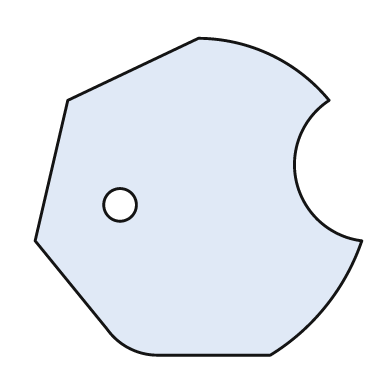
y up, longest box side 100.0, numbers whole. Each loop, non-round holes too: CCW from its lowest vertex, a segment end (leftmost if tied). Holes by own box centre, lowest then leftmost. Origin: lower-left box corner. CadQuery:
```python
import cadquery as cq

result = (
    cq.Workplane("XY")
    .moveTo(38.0, 0.0)
    .lineTo(72.0, 0.0)
    .threePointArc((89.0, 15.0), (100.0, 35.0))
    .threePointArc((80.0, 53.0), (90.0, 78.0))
    .threePointArc((72.0, 92.0), (50.0, 97.0))
    .lineTo(10.0, 78.0)
    .lineTo(0.0, 35.0)
    .lineTo(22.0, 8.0)
    .threePointArc((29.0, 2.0), (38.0, 0.0))
    .close()
    .moveTo(26.0, 46.0)
    .circle(5.0)
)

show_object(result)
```